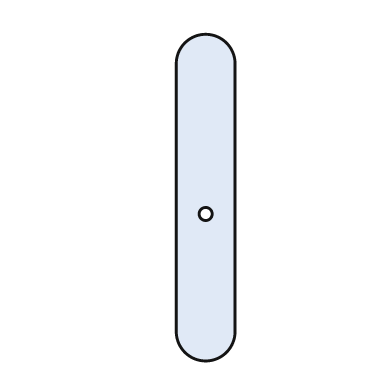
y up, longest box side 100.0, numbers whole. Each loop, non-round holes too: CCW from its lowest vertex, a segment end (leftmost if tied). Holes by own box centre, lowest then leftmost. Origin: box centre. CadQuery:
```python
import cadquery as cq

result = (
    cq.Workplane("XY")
    .moveTo(-9.0, -41.0)
    .threePointArc((0.0, -50.0), (9.0, -41.0))
    .lineTo(9.0, 41.0)
    .threePointArc((0.0, 50.0), (-9.0, 41.0))
    .close()
    .moveTo(0.0, -5.0)
    .circle(2.0)
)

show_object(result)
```